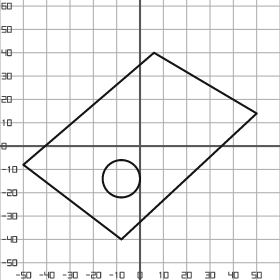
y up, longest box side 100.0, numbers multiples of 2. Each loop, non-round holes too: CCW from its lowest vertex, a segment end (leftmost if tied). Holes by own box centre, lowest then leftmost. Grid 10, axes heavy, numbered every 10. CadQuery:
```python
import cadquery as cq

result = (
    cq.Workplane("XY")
    .moveTo(-8.0, -40.0)
    .lineTo(50.0, 14.0)
    .lineTo(6.0, 40.0)
    .lineTo(-50.0, -8.0)
    .close()
    .moveTo(-8.0, -14.0)
    .circle(8.0)
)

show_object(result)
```